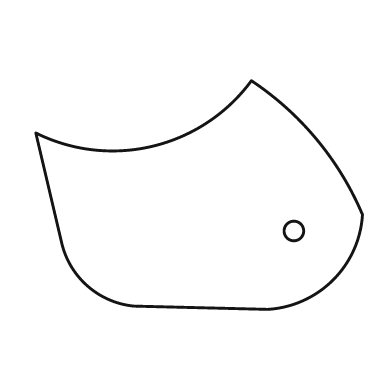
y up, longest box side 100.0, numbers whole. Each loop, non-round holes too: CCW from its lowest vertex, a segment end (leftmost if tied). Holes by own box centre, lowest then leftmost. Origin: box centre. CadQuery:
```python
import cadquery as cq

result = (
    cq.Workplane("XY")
    .moveTo(21.0, -35.0)
    .threePointArc((41.0, -26.0), (50.0, -6.0))
    .threePointArc((36.0, 17.0), (16.0, 35.0))
    .threePointArc((-14.0, 15.0), (-50.0, 19.0))
    .lineTo(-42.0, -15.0)
    .threePointArc((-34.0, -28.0), (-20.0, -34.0))
    .close()
    .moveTo(29.0, -11.0)
    .circle(3.0)
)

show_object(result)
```